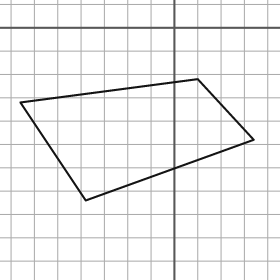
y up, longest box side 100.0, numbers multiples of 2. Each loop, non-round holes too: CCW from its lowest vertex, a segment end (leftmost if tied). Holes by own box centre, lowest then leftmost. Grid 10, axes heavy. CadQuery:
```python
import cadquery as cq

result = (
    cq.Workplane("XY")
    .moveTo(-38.0, -74.0)
    .lineTo(34.0, -48.0)
    .lineTo(10.0, -22.0)
    .lineTo(-66.0, -32.0)
    .close()
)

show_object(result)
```